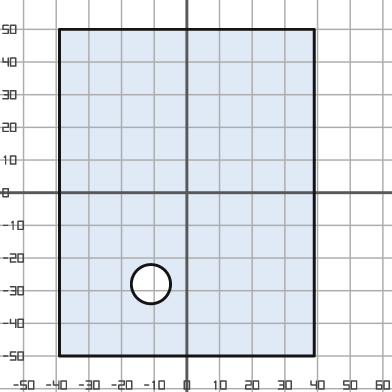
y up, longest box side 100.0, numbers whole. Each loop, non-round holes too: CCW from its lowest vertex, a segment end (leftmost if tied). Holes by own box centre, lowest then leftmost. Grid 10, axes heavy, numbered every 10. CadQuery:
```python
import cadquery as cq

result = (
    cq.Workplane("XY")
    .moveTo(-39.0, -50.0)
    .lineTo(39.0, -50.0)
    .lineTo(39.0, 50.0)
    .lineTo(-39.0, 50.0)
    .close()
    .moveTo(-11.0, -28.0)
    .circle(6.0)
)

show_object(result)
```